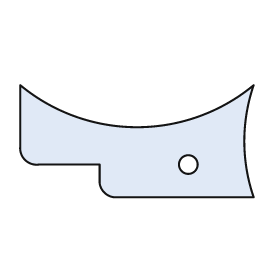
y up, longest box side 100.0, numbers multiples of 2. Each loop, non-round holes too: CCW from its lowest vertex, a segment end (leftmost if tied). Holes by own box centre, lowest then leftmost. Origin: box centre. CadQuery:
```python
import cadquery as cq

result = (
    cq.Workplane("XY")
    .moveTo(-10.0, -24.0)
    .lineTo(50.0, -24.0)
    .threePointArc((46.0, 0.0), (50.0, 24.0))
    .threePointArc((0.0, 6.0), (-50.0, 24.0))
    .lineTo(-50.0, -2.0)
    .threePointArc((-48.0, -8.0), (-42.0, -10.0))
    .lineTo(-16.0, -10.0)
    .lineTo(-16.0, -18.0)
    .threePointArc((-14.0, -22.0), (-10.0, -24.0))
    .close()
    .moveTo(22.0, -10.0)
    .circle(4.0)
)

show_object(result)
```